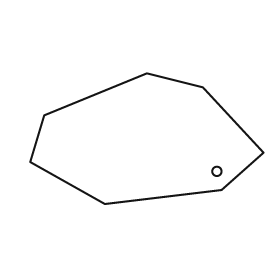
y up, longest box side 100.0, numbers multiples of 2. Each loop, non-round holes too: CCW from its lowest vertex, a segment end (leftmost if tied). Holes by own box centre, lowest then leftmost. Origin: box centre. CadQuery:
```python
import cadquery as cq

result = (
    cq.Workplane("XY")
    .moveTo(-18.0, -28.0)
    .lineTo(32.0, -22.0)
    .lineTo(50.0, -6.0)
    .lineTo(24.0, 22.0)
    .lineTo(0.0, 28.0)
    .lineTo(-44.0, 10.0)
    .lineTo(-50.0, -10.0)
    .close()
    .moveTo(30.0, -14.0)
    .circle(2.0)
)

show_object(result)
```